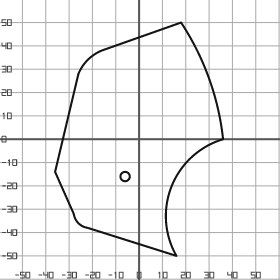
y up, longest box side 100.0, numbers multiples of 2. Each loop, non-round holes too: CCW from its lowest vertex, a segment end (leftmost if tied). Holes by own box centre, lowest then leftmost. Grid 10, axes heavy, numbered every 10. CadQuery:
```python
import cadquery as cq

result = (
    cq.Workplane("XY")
    .moveTo(16.0, -50.0)
    .threePointArc((14.0, -20.0), (36.0, 0.0))
    .threePointArc((30.0, 26.0), (18.0, 50.0))
    .lineTo(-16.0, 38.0)
    .threePointArc((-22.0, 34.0), (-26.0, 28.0))
    .lineTo(-36.0, -14.0)
    .lineTo(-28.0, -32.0)
    .threePointArc((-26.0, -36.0), (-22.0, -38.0))
    .close()
    .moveTo(-6.0, -16.0)
    .circle(2.0)
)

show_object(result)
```